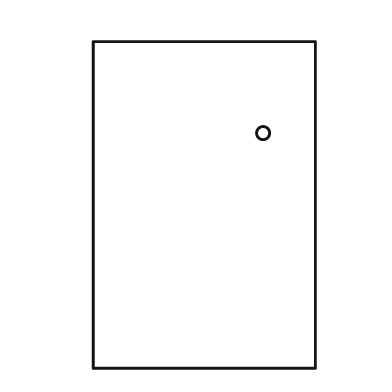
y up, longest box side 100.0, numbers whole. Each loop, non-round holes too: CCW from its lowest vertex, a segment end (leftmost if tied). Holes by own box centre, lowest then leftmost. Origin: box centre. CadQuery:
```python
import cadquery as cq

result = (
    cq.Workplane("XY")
    .moveTo(-34.0, -50.0)
    .lineTo(34.0, -50.0)
    .lineTo(34.0, 50.0)
    .lineTo(-34.0, 50.0)
    .close()
    .moveTo(18.0, 22.0)
    .circle(2.0)
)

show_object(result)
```